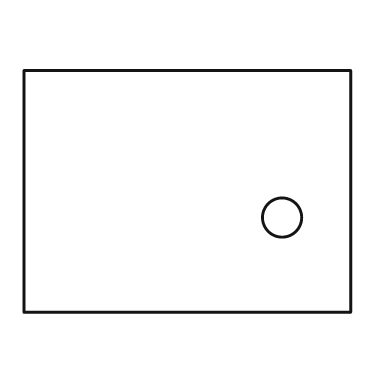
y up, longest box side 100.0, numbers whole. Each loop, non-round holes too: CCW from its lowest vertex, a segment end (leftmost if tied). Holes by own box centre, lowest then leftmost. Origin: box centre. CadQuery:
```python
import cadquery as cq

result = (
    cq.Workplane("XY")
    .moveTo(-50.0, -37.0)
    .lineTo(50.0, -37.0)
    .lineTo(50.0, 37.0)
    .lineTo(-50.0, 37.0)
    .close()
    .moveTo(29.0, -8.0)
    .circle(6.0)
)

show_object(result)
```